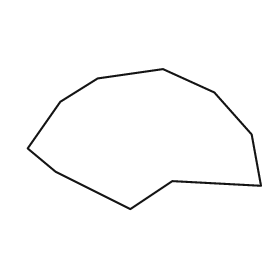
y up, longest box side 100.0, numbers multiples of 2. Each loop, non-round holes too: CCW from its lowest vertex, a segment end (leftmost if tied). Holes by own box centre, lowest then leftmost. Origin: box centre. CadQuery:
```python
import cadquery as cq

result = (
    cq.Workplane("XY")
    .moveTo(-6.0, -30.0)
    .lineTo(12.0, -18.0)
    .lineTo(50.0, -20.0)
    .lineTo(46.0, 2.0)
    .lineTo(30.0, 20.0)
    .lineTo(8.0, 30.0)
    .lineTo(-20.0, 26.0)
    .lineTo(-36.0, 16.0)
    .lineTo(-50.0, -4.0)
    .lineTo(-38.0, -14.0)
    .close()
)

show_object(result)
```